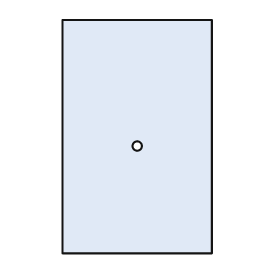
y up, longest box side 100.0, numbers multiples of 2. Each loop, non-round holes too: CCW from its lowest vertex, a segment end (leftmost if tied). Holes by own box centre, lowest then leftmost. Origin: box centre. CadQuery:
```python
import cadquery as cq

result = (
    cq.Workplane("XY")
    .moveTo(-32.0, -50.0)
    .lineTo(32.0, -50.0)
    .lineTo(32.0, 50.0)
    .lineTo(-32.0, 50.0)
    .close()
    .moveTo(0.0, -4.0)
    .circle(2.0)
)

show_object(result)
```